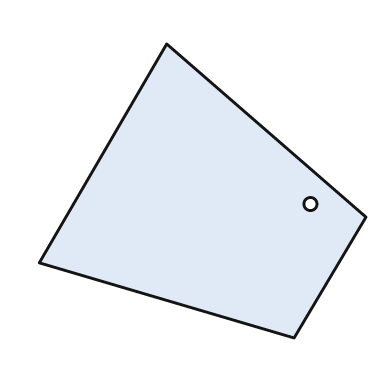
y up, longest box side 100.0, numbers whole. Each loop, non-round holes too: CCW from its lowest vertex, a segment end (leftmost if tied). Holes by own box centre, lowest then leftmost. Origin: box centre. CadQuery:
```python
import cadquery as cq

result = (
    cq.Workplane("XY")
    .moveTo(28.0, -45.0)
    .lineTo(50.0, -8.0)
    .lineTo(-11.0, 45.0)
    .lineTo(-50.0, -22.0)
    .close()
    .moveTo(33.0, -4.0)
    .circle(2.0)
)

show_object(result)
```